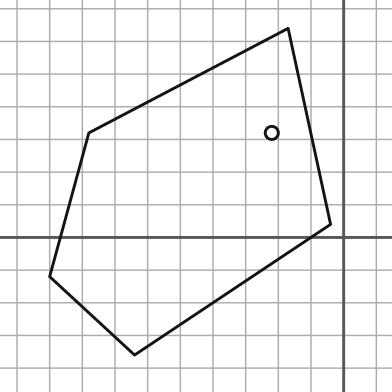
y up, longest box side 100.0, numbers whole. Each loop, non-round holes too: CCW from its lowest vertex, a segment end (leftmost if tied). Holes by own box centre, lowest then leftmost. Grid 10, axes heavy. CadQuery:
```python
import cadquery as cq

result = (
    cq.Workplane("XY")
    .moveTo(-64.0, -36.0)
    .lineTo(-4.0, 4.0)
    .lineTo(-17.0, 64.0)
    .lineTo(-78.0, 32.0)
    .lineTo(-90.0, -12.0)
    .close()
    .moveTo(-22.0, 32.0)
    .circle(2.0)
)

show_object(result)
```